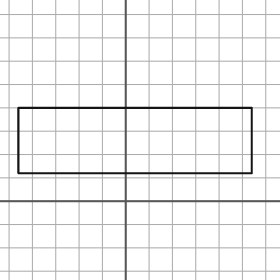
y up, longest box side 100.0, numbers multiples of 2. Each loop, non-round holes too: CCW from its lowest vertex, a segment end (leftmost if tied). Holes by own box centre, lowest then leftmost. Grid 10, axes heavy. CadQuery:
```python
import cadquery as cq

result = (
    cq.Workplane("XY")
    .moveTo(-46.0, 12.0)
    .lineTo(54.0, 12.0)
    .lineTo(54.0, 40.0)
    .lineTo(-46.0, 40.0)
    .close()
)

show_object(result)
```